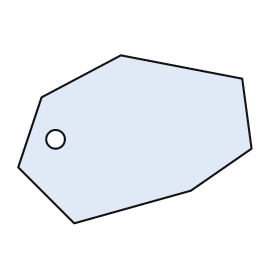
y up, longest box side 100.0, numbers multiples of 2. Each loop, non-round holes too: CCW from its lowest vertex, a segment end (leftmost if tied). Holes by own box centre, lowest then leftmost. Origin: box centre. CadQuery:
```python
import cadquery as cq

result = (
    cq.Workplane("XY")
    .moveTo(-26.0, -36.0)
    .lineTo(24.0, -22.0)
    .lineTo(50.0, -4.0)
    .lineTo(46.0, 26.0)
    .lineTo(-6.0, 36.0)
    .lineTo(-40.0, 18.0)
    .lineTo(-50.0, -12.0)
    .close()
    .moveTo(-34.0, 0.0)
    .circle(4.0)
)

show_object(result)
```